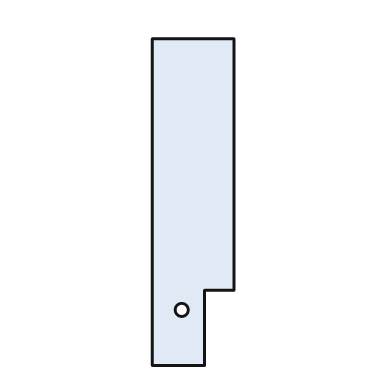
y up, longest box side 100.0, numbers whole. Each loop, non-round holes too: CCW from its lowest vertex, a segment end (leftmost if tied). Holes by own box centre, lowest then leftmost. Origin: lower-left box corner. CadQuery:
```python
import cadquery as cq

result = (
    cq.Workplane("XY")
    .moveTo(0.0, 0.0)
    .lineTo(16.0, 0.0)
    .lineTo(16.0, 23.0)
    .lineTo(25.0, 23.0)
    .lineTo(25.0, 100.0)
    .lineTo(0.0, 100.0)
    .close()
    .moveTo(9.0, 17.0)
    .circle(2.0)
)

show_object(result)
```